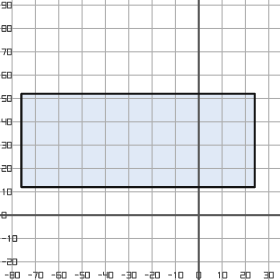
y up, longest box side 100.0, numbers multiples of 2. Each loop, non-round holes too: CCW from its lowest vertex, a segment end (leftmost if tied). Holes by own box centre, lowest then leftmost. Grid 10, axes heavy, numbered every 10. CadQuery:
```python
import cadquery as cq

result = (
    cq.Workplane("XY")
    .moveTo(-76.0, 12.0)
    .lineTo(24.0, 12.0)
    .lineTo(24.0, 52.0)
    .lineTo(-76.0, 52.0)
    .close()
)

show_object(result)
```